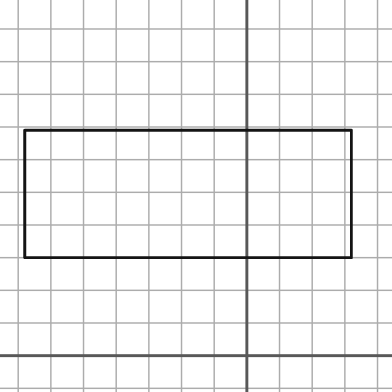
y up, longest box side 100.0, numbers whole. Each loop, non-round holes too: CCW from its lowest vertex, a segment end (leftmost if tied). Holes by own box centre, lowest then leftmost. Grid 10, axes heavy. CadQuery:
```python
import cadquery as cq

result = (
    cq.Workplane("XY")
    .moveTo(-68.0, 30.0)
    .lineTo(32.0, 30.0)
    .lineTo(32.0, 69.0)
    .lineTo(-68.0, 69.0)
    .close()
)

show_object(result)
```